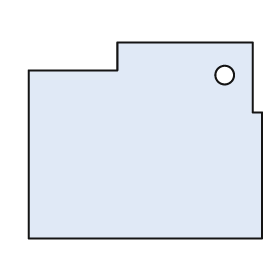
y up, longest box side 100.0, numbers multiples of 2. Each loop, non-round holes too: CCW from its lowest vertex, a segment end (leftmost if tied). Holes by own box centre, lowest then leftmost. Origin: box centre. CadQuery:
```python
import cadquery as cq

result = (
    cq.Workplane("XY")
    .moveTo(-50.0, -42.0)
    .lineTo(50.0, -42.0)
    .lineTo(50.0, 12.0)
    .lineTo(46.0, 12.0)
    .lineTo(46.0, 42.0)
    .lineTo(-12.0, 42.0)
    .lineTo(-12.0, 30.0)
    .lineTo(-50.0, 30.0)
    .close()
    .moveTo(34.0, 28.0)
    .circle(4.0)
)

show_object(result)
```